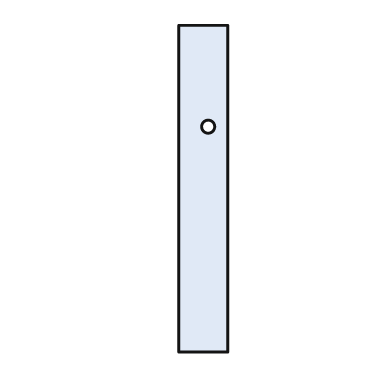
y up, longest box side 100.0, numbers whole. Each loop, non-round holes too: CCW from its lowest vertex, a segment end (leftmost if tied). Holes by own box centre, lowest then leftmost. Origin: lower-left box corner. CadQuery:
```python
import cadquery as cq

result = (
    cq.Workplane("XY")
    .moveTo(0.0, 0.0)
    .lineTo(15.0, 0.0)
    .lineTo(15.0, 100.0)
    .lineTo(0.0, 100.0)
    .close()
    .moveTo(9.0, 69.0)
    .circle(2.0)
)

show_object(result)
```